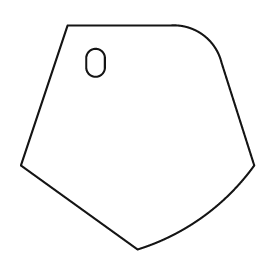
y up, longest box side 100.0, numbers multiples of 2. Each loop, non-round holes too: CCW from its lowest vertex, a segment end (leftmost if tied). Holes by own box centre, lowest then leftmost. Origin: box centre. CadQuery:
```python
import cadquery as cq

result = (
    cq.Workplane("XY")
    .moveTo(0.0, -48.0)
    .threePointArc((28.0, -34.0), (50.0, -12.0))
    .lineTo(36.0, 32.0)
    .threePointArc((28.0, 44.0), (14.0, 48.0))
    .lineTo(-30.0, 48.0)
    .lineTo(-50.0, -12.0)
    .close()
    .moveTo(-22.0, 30.0)
    .threePointArc((-18.0, 26.0), (-14.0, 30.0))
    .lineTo(-14.0, 34.0)
    .threePointArc((-18.0, 38.0), (-22.0, 34.0))
    .close()
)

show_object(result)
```